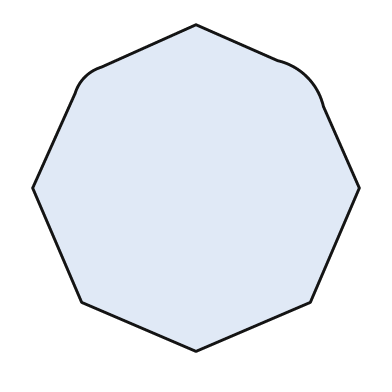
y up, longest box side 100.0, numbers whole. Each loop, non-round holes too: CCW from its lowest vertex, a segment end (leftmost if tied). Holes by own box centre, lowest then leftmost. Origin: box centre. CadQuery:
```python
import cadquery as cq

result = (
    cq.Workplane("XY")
    .moveTo(0.0, -50.0)
    .lineTo(35.0, -35.0)
    .lineTo(50.0, 0.0)
    .lineTo(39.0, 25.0)
    .threePointArc((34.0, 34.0), (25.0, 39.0))
    .lineTo(0.0, 50.0)
    .lineTo(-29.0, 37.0)
    .threePointArc((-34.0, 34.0), (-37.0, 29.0))
    .lineTo(-50.0, 0.0)
    .lineTo(-35.0, -35.0)
    .close()
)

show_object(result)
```